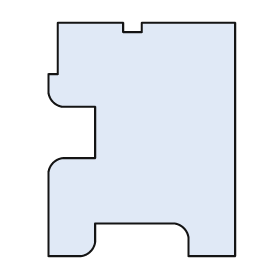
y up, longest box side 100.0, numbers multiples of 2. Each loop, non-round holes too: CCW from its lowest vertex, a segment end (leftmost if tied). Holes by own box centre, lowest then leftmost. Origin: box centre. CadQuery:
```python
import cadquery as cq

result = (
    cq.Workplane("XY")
    .moveTo(-40.0, -50.0)
    .lineTo(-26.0, -50.0)
    .threePointArc((-22.0, -48.0), (-20.0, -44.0))
    .lineTo(-20.0, -36.0)
    .lineTo(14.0, -36.0)
    .threePointArc((18.0, -38.0), (20.0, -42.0))
    .lineTo(20.0, -50.0)
    .lineTo(40.0, -50.0)
    .lineTo(40.0, 50.0)
    .lineTo(0.0, 50.0)
    .lineTo(0.0, 46.0)
    .lineTo(-8.0, 46.0)
    .lineTo(-8.0, 50.0)
    .lineTo(-36.0, 50.0)
    .lineTo(-36.0, 28.0)
    .lineTo(-40.0, 28.0)
    .lineTo(-40.0, 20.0)
    .threePointArc((-38.0, 16.0), (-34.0, 14.0))
    .lineTo(-20.0, 14.0)
    .lineTo(-20.0, -8.0)
    .lineTo(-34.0, -8.0)
    .threePointArc((-38.0, -10.0), (-40.0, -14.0))
    .close()
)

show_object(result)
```